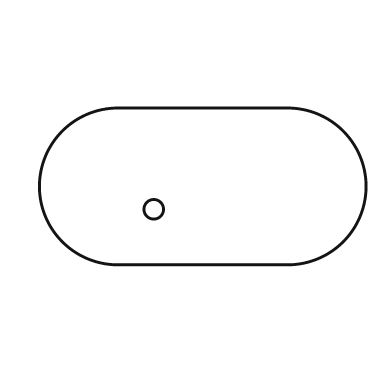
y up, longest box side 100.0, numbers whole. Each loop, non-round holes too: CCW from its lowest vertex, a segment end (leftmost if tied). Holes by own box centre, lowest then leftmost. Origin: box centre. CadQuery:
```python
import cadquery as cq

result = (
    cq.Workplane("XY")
    .moveTo(-26.0, -24.0)
    .lineTo(26.0, -24.0)
    .threePointArc((50.0, 0.0), (26.0, 24.0))
    .lineTo(-26.0, 24.0)
    .threePointArc((-50.0, 0.0), (-26.0, -24.0))
    .close()
    .moveTo(-15.0, -7.0)
    .circle(3.0)
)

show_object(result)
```